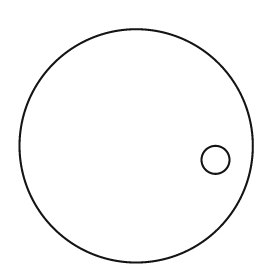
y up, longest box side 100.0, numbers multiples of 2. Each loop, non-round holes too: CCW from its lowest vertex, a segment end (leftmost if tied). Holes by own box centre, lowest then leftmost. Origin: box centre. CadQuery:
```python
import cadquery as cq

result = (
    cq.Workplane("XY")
    .moveTo(0.0, 0.0)
    .circle(50.0)
    .moveTo(34.0, -6.0)
    .circle(6.0)
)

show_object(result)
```